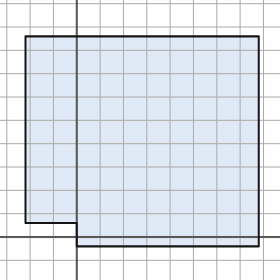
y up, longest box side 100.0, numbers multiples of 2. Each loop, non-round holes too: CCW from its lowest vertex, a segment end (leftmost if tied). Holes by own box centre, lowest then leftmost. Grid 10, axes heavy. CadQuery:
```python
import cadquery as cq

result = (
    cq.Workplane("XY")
    .moveTo(0.0, -4.0)
    .lineTo(78.0, -4.0)
    .lineTo(78.0, 86.0)
    .lineTo(-22.0, 86.0)
    .lineTo(-22.0, 6.0)
    .lineTo(0.0, 6.0)
    .close()
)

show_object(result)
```